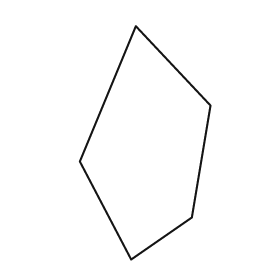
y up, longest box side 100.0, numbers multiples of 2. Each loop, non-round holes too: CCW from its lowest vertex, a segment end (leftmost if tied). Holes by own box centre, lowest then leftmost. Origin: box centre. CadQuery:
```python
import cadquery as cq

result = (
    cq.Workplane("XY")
    .moveTo(-6.0, -50.0)
    .lineTo(20.0, -32.0)
    .lineTo(28.0, 16.0)
    .lineTo(-4.0, 50.0)
    .lineTo(-28.0, -8.0)
    .close()
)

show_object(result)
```